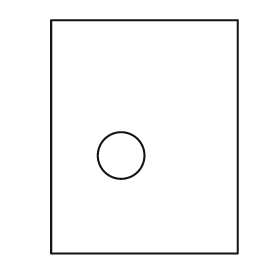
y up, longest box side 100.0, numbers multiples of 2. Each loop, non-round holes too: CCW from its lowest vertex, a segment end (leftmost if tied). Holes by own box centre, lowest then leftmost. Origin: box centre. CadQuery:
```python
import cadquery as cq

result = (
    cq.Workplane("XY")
    .moveTo(-40.0, -50.0)
    .lineTo(40.0, -50.0)
    .lineTo(40.0, 50.0)
    .lineTo(-40.0, 50.0)
    .close()
    .moveTo(-10.0, -8.0)
    .circle(10.0)
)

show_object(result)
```